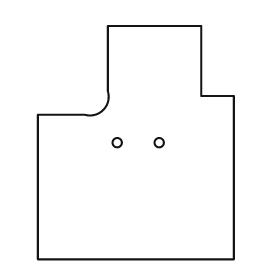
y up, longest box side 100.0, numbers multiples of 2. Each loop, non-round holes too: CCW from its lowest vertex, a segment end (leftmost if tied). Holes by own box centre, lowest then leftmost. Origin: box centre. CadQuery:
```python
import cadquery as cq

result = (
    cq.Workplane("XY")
    .moveTo(-42.0, -50.0)
    .lineTo(42.0, -50.0)
    .lineTo(42.0, 20.0)
    .lineTo(28.0, 20.0)
    .lineTo(28.0, 50.0)
    .lineTo(-12.0, 50.0)
    .lineTo(-12.0, 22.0)
    .threePointArc((-14.0, 14.0), (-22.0, 12.0))
    .lineTo(-42.0, 12.0)
    .close()
    .moveTo(-8.0, 0.0)
    .circle(2.0)
    .moveTo(10.0, 0.0)
    .circle(2.0)
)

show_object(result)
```